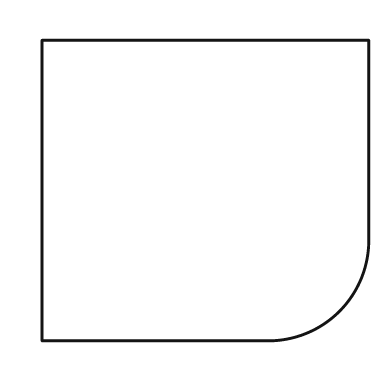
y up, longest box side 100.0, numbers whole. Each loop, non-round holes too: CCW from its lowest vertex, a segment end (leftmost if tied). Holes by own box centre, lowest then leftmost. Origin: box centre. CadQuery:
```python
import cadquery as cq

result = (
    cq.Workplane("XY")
    .moveTo(-50.0, -46.0)
    .lineTo(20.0, -46.0)
    .threePointArc((41.0, -37.0), (50.0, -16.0))
    .lineTo(50.0, 46.0)
    .lineTo(-50.0, 46.0)
    .close()
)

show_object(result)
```